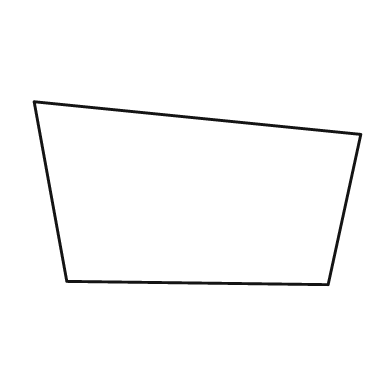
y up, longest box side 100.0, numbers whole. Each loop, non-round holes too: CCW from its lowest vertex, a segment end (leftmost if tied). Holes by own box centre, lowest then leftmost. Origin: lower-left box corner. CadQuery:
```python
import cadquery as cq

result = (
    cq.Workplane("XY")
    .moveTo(90.0, 0.0)
    .lineTo(100.0, 46.0)
    .lineTo(0.0, 56.0)
    .lineTo(10.0, 1.0)
    .close()
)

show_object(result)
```